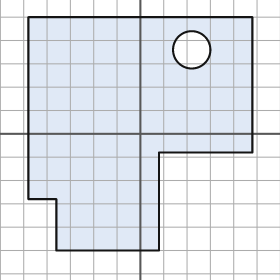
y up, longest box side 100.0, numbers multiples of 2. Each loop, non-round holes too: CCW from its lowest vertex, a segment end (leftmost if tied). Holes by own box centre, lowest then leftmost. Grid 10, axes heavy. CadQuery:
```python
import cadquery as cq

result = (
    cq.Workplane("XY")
    .moveTo(-36.0, -50.0)
    .lineTo(8.0, -50.0)
    .lineTo(8.0, -8.0)
    .lineTo(48.0, -8.0)
    .lineTo(48.0, 50.0)
    .lineTo(-48.0, 50.0)
    .lineTo(-48.0, -28.0)
    .lineTo(-36.0, -28.0)
    .close()
    .moveTo(22.0, 36.0)
    .circle(8.0)
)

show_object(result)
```